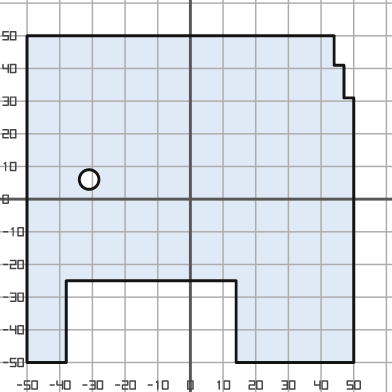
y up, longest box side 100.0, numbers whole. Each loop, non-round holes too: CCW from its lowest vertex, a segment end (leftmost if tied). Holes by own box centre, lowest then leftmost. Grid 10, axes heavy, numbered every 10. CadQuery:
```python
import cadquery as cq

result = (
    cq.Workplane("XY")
    .moveTo(-50.0, -50.0)
    .lineTo(-38.0, -50.0)
    .lineTo(-38.0, -25.0)
    .lineTo(14.0, -25.0)
    .lineTo(14.0, -50.0)
    .lineTo(50.0, -50.0)
    .lineTo(50.0, 31.0)
    .lineTo(47.0, 31.0)
    .lineTo(47.0, 41.0)
    .lineTo(44.0, 41.0)
    .lineTo(44.0, 50.0)
    .lineTo(-50.0, 50.0)
    .close()
    .moveTo(-31.0, 6.0)
    .circle(3.0)
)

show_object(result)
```